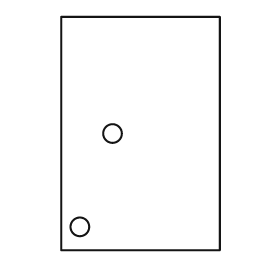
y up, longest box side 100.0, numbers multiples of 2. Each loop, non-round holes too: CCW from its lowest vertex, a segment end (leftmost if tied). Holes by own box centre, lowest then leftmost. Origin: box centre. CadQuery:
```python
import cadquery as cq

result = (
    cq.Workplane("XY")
    .moveTo(-34.0, -50.0)
    .lineTo(34.0, -50.0)
    .lineTo(34.0, 50.0)
    .lineTo(-34.0, 50.0)
    .close()
    .moveTo(-26.0, -40.0)
    .circle(4.0)
    .moveTo(-12.0, 0.0)
    .circle(4.0)
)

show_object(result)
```